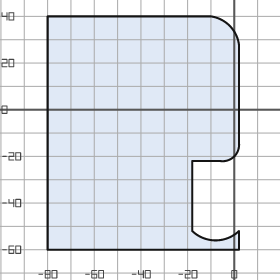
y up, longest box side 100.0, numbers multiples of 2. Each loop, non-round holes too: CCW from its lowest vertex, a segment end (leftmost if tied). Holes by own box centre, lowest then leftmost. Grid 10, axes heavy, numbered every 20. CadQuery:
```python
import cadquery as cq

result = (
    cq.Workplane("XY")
    .moveTo(-80.0, -60.0)
    .lineTo(2.0, -60.0)
    .lineTo(2.0, -52.0)
    .threePointArc((-8.0, -56.0), (-18.0, -52.0))
    .lineTo(-18.0, -22.0)
    .lineTo(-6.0, -22.0)
    .threePointArc((0.0, -20.0), (2.0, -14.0))
    .lineTo(2.0, 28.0)
    .threePointArc((-2.0, 36.0), (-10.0, 40.0))
    .lineTo(-80.0, 40.0)
    .close()
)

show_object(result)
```